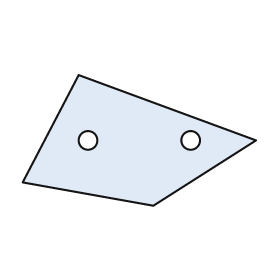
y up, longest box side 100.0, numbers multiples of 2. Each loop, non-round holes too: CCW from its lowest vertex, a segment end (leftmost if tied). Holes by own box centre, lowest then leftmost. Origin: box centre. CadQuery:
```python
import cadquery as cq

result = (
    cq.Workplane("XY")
    .moveTo(6.0, -28.0)
    .lineTo(50.0, 0.0)
    .lineTo(-26.0, 28.0)
    .lineTo(-50.0, -18.0)
    .close()
    .moveTo(-22.0, 0.0)
    .circle(4.0)
    .moveTo(22.0, 0.0)
    .circle(4.0)
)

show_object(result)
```